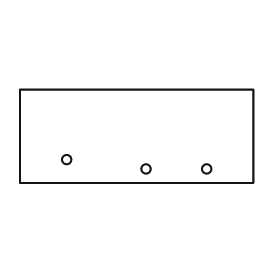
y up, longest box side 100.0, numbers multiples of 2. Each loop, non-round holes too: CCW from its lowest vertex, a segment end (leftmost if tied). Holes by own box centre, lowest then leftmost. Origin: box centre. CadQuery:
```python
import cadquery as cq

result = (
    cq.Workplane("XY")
    .moveTo(-50.0, -20.0)
    .lineTo(50.0, -20.0)
    .lineTo(50.0, 20.0)
    .lineTo(-50.0, 20.0)
    .close()
    .moveTo(4.0, -14.0)
    .circle(2.0)
    .moveTo(30.0, -14.0)
    .circle(2.0)
    .moveTo(-30.0, -10.0)
    .circle(2.0)
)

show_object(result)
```